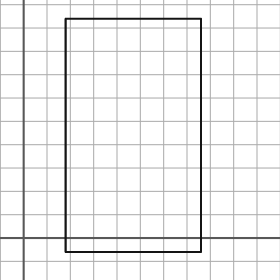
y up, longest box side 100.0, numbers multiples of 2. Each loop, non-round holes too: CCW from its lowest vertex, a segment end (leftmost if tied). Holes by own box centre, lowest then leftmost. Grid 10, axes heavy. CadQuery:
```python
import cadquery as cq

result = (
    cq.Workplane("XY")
    .moveTo(18.0, -6.0)
    .lineTo(76.0, -6.0)
    .lineTo(76.0, 94.0)
    .lineTo(18.0, 94.0)
    .close()
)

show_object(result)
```